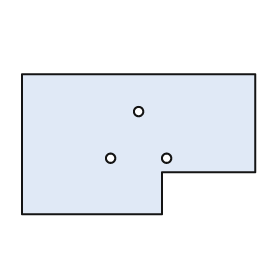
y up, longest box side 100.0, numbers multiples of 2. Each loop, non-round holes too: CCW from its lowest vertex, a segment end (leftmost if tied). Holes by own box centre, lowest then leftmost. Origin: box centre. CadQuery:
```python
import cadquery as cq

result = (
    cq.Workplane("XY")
    .moveTo(-50.0, -30.0)
    .lineTo(10.0, -30.0)
    .lineTo(10.0, -12.0)
    .lineTo(50.0, -12.0)
    .lineTo(50.0, 30.0)
    .lineTo(-50.0, 30.0)
    .close()
    .moveTo(-12.0, -6.0)
    .circle(2.0)
    .moveTo(12.0, -6.0)
    .circle(2.0)
    .moveTo(0.0, 14.0)
    .circle(2.0)
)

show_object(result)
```